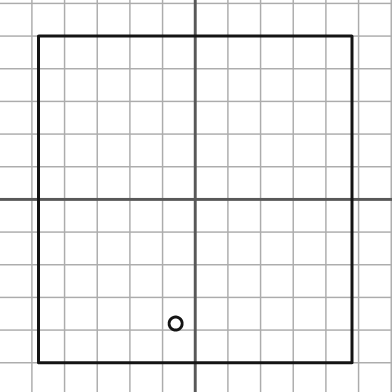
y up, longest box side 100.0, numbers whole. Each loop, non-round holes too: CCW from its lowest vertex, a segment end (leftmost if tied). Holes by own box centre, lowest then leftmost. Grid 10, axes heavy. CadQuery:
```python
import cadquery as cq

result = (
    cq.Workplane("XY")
    .moveTo(-48.0, -50.0)
    .lineTo(48.0, -50.0)
    .lineTo(48.0, 50.0)
    .lineTo(-48.0, 50.0)
    .close()
    .moveTo(-6.0, -38.0)
    .circle(2.0)
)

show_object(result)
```